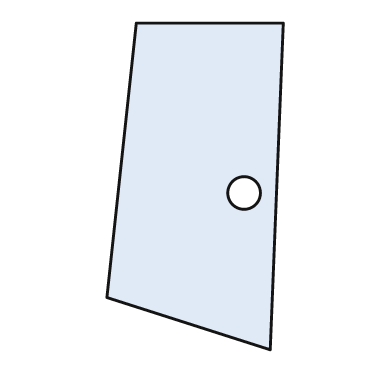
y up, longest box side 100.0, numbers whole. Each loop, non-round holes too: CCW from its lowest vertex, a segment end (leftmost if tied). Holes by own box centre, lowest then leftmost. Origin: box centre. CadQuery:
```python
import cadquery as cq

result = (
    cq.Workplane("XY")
    .moveTo(23.0, -50.0)
    .lineTo(27.0, 50.0)
    .lineTo(-18.0, 50.0)
    .lineTo(-27.0, -34.0)
    .close()
    .moveTo(15.0, -2.0)
    .circle(5.0)
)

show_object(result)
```